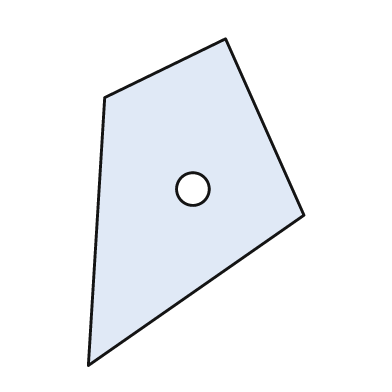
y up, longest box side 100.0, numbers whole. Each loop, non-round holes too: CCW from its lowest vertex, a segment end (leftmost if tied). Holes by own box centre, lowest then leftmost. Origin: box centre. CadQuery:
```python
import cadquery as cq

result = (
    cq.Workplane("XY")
    .moveTo(-33.0, -50.0)
    .lineTo(33.0, -4.0)
    .lineTo(9.0, 50.0)
    .lineTo(-28.0, 32.0)
    .close()
    .moveTo(-1.0, 4.0)
    .circle(5.0)
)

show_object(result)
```